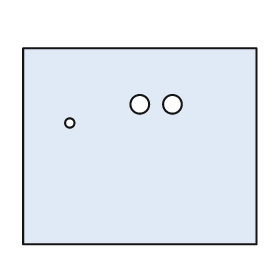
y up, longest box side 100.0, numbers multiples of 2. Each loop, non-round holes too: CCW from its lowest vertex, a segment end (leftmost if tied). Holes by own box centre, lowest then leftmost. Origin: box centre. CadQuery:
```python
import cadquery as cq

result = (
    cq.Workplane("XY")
    .moveTo(-50.0, -42.0)
    .lineTo(50.0, -42.0)
    .lineTo(50.0, 42.0)
    .lineTo(-50.0, 42.0)
    .close()
    .moveTo(-30.0, 10.0)
    .circle(2.0)
    .moveTo(0.0, 18.0)
    .circle(4.0)
    .moveTo(14.0, 18.0)
    .circle(4.0)
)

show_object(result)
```